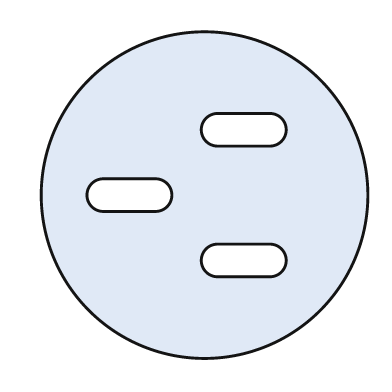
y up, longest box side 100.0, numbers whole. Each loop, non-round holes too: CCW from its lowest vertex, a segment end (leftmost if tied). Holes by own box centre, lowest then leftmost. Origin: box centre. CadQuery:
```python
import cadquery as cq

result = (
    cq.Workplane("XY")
    .moveTo(0.0, 0.0)
    .circle(50.0)
    .moveTo(4.0, -25.0)
    .lineTo(20.0, -25.0)
    .threePointArc((25.0, -20.0), (20.0, -15.0))
    .lineTo(4.0, -15.0)
    .threePointArc((-1.0, -20.0), (4.0, -25.0))
    .close()
    .moveTo(-31.0, -5.0)
    .lineTo(-15.0, -5.0)
    .threePointArc((-10.0, 0.0), (-15.0, 5.0))
    .lineTo(-31.0, 5.0)
    .threePointArc((-36.0, 0.0), (-31.0, -5.0))
    .close()
    .moveTo(4.0, 15.0)
    .lineTo(20.0, 15.0)
    .threePointArc((25.0, 20.0), (20.0, 25.0))
    .lineTo(4.0, 25.0)
    .threePointArc((-1.0, 20.0), (4.0, 15.0))
    .close()
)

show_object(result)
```